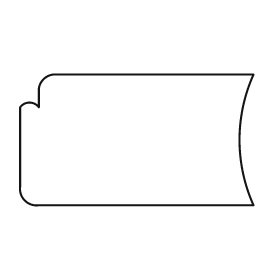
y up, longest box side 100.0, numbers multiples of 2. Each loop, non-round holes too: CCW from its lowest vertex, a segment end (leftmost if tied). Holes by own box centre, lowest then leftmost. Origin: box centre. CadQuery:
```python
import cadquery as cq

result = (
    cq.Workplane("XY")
    .moveTo(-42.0, -28.0)
    .lineTo(50.0, -28.0)
    .threePointArc((44.0, 0.0), (50.0, 28.0))
    .lineTo(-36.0, 28.0)
    .threePointArc((-40.0, 26.0), (-42.0, 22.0))
    .lineTo(-42.0, 14.0)
    .threePointArc((-46.0, 16.0), (-50.0, 14.0))
    .lineTo(-50.0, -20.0)
    .threePointArc((-48.0, -26.0), (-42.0, -28.0))
    .close()
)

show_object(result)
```